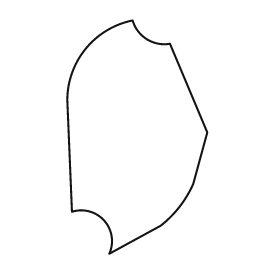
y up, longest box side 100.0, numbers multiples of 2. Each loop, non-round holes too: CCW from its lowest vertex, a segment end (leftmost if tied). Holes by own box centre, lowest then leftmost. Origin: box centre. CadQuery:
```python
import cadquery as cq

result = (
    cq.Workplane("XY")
    .moveTo(-12.0, -50.0)
    .lineTo(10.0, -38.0)
    .threePointArc((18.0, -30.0), (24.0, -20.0))
    .lineTo(30.0, 2.0)
    .lineTo(14.0, 40.0)
    .threePointArc((4.0, 42.0), (-2.0, 50.0))
    .threePointArc((-22.0, 38.0), (-30.0, 16.0))
    .lineTo(-28.0, -32.0)
    .threePointArc((-14.0, -36.0), (-12.0, -50.0))
    .close()
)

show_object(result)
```